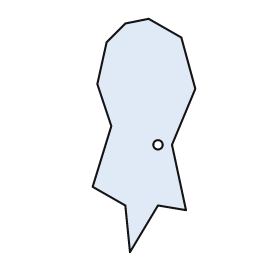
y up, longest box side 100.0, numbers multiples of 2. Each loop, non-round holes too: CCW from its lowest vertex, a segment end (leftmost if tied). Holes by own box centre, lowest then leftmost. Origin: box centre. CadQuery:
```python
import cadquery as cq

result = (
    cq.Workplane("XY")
    .moveTo(-6.0, -50.0)
    .lineTo(6.0, -30.0)
    .lineTo(18.0, -32.0)
    .lineTo(12.0, -4.0)
    .lineTo(22.0, 20.0)
    .lineTo(16.0, 42.0)
    .lineTo(2.0, 50.0)
    .lineTo(-8.0, 48.0)
    .lineTo(-16.0, 40.0)
    .lineTo(-20.0, 22.0)
    .lineTo(-14.0, 4.0)
    .lineTo(-22.0, -22.0)
    .lineTo(-8.0, -30.0)
    .close()
    .moveTo(6.0, -4.0)
    .circle(2.0)
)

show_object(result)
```